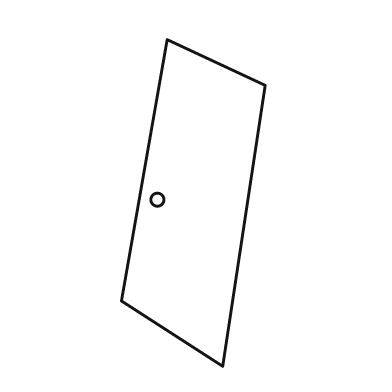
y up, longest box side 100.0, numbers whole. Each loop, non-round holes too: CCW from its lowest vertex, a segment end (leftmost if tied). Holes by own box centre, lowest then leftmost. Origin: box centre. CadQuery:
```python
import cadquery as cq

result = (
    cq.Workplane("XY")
    .moveTo(9.0, -50.0)
    .lineTo(22.0, 36.0)
    .lineTo(-8.0, 50.0)
    .lineTo(-22.0, -30.0)
    .close()
    .moveTo(-11.0, 1.0)
    .circle(2.0)
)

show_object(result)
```